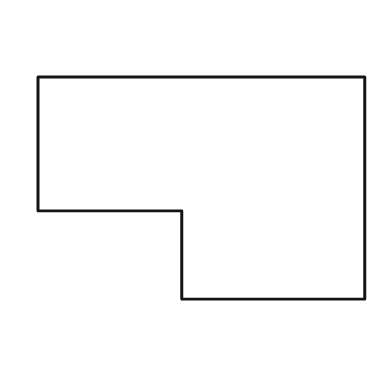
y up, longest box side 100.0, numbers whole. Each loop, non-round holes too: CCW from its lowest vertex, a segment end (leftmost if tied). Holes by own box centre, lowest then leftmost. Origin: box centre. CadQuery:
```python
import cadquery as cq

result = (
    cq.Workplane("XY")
    .moveTo(-6.0, -34.0)
    .lineTo(50.0, -34.0)
    .lineTo(50.0, 34.0)
    .lineTo(-50.0, 34.0)
    .lineTo(-50.0, -7.0)
    .lineTo(-6.0, -7.0)
    .close()
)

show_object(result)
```